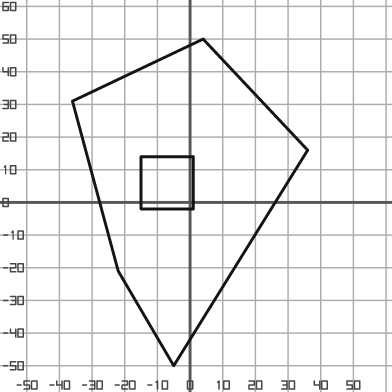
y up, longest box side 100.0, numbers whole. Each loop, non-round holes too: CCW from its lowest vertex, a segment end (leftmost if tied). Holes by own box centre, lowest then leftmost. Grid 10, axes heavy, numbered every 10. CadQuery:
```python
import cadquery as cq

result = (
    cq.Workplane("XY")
    .moveTo(-5.0, -50.0)
    .lineTo(36.0, 16.0)
    .lineTo(4.0, 50.0)
    .lineTo(-36.0, 31.0)
    .lineTo(-22.0, -21.0)
    .close()
    .moveTo(-15.0, -2.0)
    .lineTo(1.0, -2.0)
    .lineTo(1.0, 14.0)
    .lineTo(-15.0, 14.0)
    .close()
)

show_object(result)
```